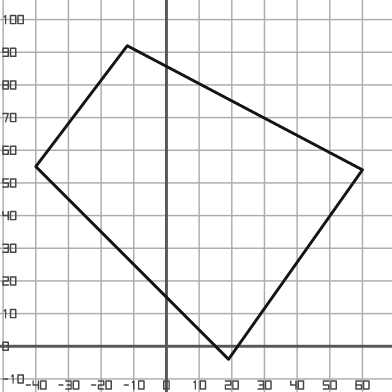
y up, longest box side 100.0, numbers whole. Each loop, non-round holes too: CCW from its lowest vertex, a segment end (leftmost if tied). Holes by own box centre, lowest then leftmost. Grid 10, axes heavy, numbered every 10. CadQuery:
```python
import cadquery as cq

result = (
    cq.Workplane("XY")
    .moveTo(19.0, -4.0)
    .lineTo(60.0, 54.0)
    .lineTo(-12.0, 92.0)
    .lineTo(-40.0, 55.0)
    .close()
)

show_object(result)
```